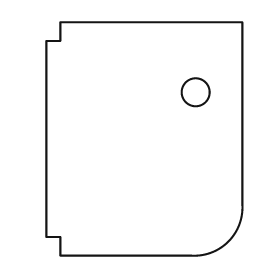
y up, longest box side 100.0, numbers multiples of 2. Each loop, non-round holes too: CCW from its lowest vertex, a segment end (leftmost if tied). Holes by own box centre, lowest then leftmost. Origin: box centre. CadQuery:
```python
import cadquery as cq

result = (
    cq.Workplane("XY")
    .moveTo(-36.0, -50.0)
    .lineTo(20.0, -50.0)
    .threePointArc((36.0, -44.0), (42.0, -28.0))
    .lineTo(42.0, 50.0)
    .lineTo(-36.0, 50.0)
    .lineTo(-36.0, 42.0)
    .lineTo(-42.0, 42.0)
    .lineTo(-42.0, -42.0)
    .lineTo(-36.0, -42.0)
    .close()
    .moveTo(22.0, 20.0)
    .circle(6.0)
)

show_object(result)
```